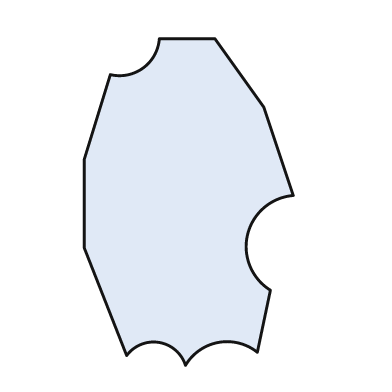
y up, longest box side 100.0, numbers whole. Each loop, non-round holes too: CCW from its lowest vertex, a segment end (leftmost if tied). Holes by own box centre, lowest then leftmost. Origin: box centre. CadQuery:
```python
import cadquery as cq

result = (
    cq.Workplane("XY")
    .moveTo(-1.0, -50.0)
    .threePointArc((9.0, -43.0), (21.0, -46.0))
    .lineTo(25.0, -27.0)
    .threePointArc((18.0, -10.0), (32.0, 2.0))
    .lineTo(23.0, 29.0)
    .lineTo(8.0, 50.0)
    .lineTo(-9.0, 50.0)
    .threePointArc((-14.0, 41.0), (-24.0, 39.0))
    .lineTo(-32.0, 13.0)
    .lineTo(-32.0, -14.0)
    .lineTo(-19.0, -47.0)
    .threePointArc((-9.0, -43.0), (-1.0, -50.0))
    .close()
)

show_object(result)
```